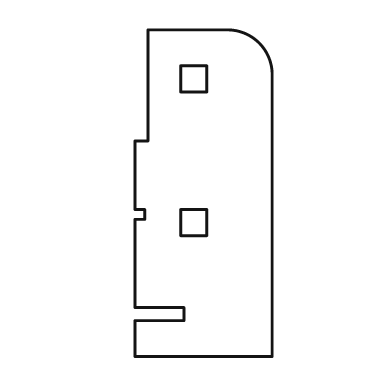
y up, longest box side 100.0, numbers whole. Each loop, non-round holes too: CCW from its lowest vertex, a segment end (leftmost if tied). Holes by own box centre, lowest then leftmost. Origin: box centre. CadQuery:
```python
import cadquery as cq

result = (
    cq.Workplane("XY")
    .moveTo(-21.0, -50.0)
    .lineTo(21.0, -50.0)
    .lineTo(21.0, 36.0)
    .threePointArc((17.0, 46.0), (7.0, 50.0))
    .lineTo(-17.0, 50.0)
    .lineTo(-17.0, 16.0)
    .lineTo(-21.0, 16.0)
    .lineTo(-21.0, -5.0)
    .lineTo(-18.0, -5.0)
    .lineTo(-18.0, -8.0)
    .lineTo(-21.0, -8.0)
    .lineTo(-21.0, -35.0)
    .lineTo(-6.0, -35.0)
    .lineTo(-6.0, -39.0)
    .lineTo(-21.0, -39.0)
    .close()
    .moveTo(-7.0, -13.0)
    .lineTo(1.0, -13.0)
    .lineTo(1.0, -5.0)
    .lineTo(-7.0, -5.0)
    .close()
    .moveTo(-7.0, 31.0)
    .lineTo(1.0, 31.0)
    .lineTo(1.0, 39.0)
    .lineTo(-7.0, 39.0)
    .close()
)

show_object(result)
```